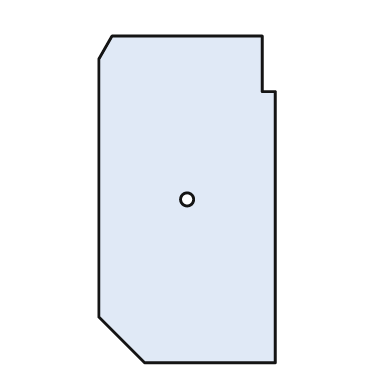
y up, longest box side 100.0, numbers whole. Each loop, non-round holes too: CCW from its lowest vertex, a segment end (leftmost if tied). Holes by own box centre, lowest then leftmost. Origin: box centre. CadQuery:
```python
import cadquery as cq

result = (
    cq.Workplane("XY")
    .moveTo(-13.0, -50.0)
    .lineTo(27.0, -50.0)
    .lineTo(27.0, 33.0)
    .lineTo(23.0, 33.0)
    .lineTo(23.0, 50.0)
    .lineTo(-23.0, 50.0)
    .lineTo(-27.0, 43.0)
    .lineTo(-27.0, -36.0)
    .close()
    .moveTo(0.0, 0.0)
    .circle(2.0)
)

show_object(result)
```